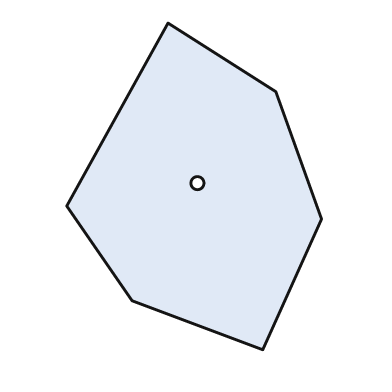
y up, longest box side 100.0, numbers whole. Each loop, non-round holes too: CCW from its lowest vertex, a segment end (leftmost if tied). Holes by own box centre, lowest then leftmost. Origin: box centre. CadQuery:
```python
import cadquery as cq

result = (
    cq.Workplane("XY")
    .moveTo(21.0, -50.0)
    .lineTo(39.0, -10.0)
    .lineTo(25.0, 29.0)
    .lineTo(-8.0, 50.0)
    .lineTo(-39.0, -6.0)
    .lineTo(-19.0, -35.0)
    .close()
    .moveTo(1.0, 1.0)
    .circle(2.0)
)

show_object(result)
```